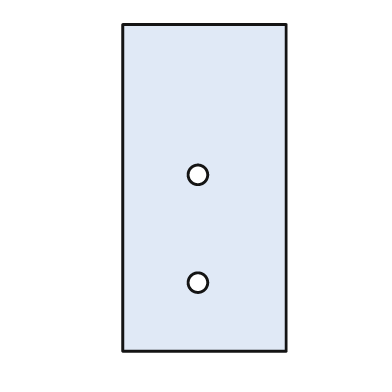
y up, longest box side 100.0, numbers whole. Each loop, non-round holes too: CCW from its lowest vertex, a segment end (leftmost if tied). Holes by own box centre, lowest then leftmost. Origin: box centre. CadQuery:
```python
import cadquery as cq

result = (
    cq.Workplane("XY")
    .moveTo(-25.0, -50.0)
    .lineTo(25.0, -50.0)
    .lineTo(25.0, 50.0)
    .lineTo(-25.0, 50.0)
    .close()
    .moveTo(-2.0, -29.0)
    .circle(3.0)
    .moveTo(-2.0, 4.0)
    .circle(3.0)
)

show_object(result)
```